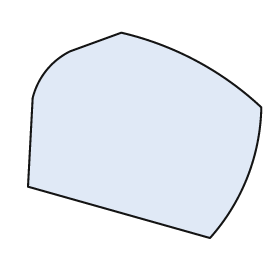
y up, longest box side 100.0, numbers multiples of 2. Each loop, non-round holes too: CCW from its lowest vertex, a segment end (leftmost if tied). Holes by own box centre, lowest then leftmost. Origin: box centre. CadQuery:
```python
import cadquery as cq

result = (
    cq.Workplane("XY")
    .moveTo(28.0, -44.0)
    .threePointArc((44.0, -18.0), (50.0, 12.0))
    .threePointArc((22.0, 32.0), (-10.0, 44.0))
    .lineTo(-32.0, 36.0)
    .threePointArc((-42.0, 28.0), (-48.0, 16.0))
    .lineTo(-50.0, -22.0)
    .close()
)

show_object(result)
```